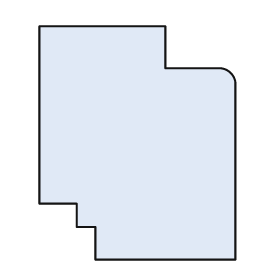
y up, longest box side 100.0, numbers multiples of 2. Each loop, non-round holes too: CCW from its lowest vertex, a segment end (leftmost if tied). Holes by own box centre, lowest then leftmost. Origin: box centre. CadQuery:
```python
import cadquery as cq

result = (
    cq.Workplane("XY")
    .moveTo(-18.0, -50.0)
    .lineTo(42.0, -50.0)
    .lineTo(42.0, 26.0)
    .threePointArc((40.0, 30.0), (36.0, 32.0))
    .lineTo(12.0, 32.0)
    .lineTo(12.0, 50.0)
    .lineTo(-42.0, 50.0)
    .lineTo(-42.0, -26.0)
    .lineTo(-26.0, -26.0)
    .lineTo(-26.0, -36.0)
    .lineTo(-18.0, -36.0)
    .close()
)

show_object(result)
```